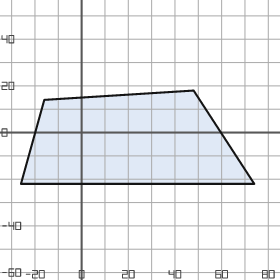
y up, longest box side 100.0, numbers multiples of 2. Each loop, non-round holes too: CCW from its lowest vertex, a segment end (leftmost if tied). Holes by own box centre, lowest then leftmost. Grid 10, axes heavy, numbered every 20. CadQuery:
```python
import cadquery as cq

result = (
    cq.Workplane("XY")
    .moveTo(-26.0, -22.0)
    .lineTo(74.0, -22.0)
    .lineTo(48.0, 18.0)
    .lineTo(-16.0, 14.0)
    .close()
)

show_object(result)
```